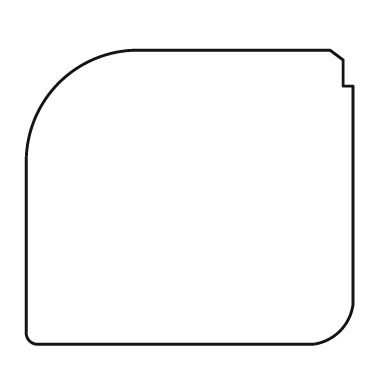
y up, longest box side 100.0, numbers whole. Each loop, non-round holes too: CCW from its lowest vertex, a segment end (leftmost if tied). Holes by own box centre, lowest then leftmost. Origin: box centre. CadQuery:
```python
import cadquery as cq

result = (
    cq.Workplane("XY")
    .moveTo(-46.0, -45.0)
    .lineTo(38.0, -45.0)
    .threePointArc((46.0, -41.0), (50.0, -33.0))
    .lineTo(50.0, 34.0)
    .lineTo(47.0, 34.0)
    .lineTo(47.0, 42.0)
    .lineTo(43.0, 45.0)
    .lineTo(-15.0, 45.0)
    .threePointArc((-40.0, 35.0), (-50.0, 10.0))
    .lineTo(-50.0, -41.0)
    .threePointArc((-49.0, -44.0), (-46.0, -45.0))
    .close()
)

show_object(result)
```